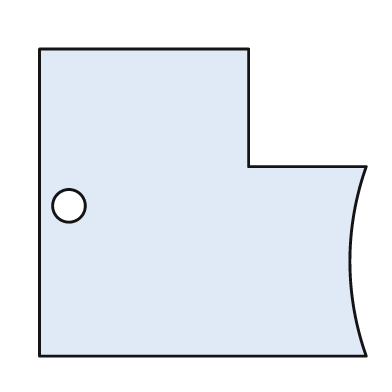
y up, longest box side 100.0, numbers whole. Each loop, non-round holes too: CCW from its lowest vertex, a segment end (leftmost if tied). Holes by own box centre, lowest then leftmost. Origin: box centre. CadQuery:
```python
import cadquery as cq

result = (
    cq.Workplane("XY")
    .moveTo(-50.0, -47.0)
    .lineTo(50.0, -47.0)
    .threePointArc((45.0, -18.0), (50.0, 11.0))
    .lineTo(14.0, 11.0)
    .lineTo(14.0, 47.0)
    .lineTo(-50.0, 47.0)
    .close()
    .moveTo(-41.0, -1.0)
    .circle(5.0)
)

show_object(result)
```